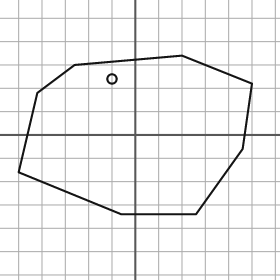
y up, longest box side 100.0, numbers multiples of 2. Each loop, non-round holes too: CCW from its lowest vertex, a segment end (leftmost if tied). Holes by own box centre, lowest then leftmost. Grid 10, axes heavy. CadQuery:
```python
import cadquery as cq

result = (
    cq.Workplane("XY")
    .moveTo(-6.0, -34.0)
    .lineTo(26.0, -34.0)
    .lineTo(46.0, -6.0)
    .lineTo(50.0, 22.0)
    .lineTo(20.0, 34.0)
    .lineTo(-26.0, 30.0)
    .lineTo(-42.0, 18.0)
    .lineTo(-50.0, -16.0)
    .close()
    .moveTo(-10.0, 24.0)
    .circle(2.0)
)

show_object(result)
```